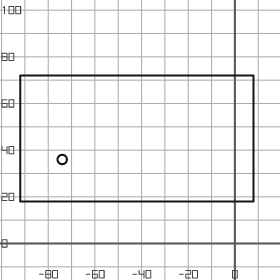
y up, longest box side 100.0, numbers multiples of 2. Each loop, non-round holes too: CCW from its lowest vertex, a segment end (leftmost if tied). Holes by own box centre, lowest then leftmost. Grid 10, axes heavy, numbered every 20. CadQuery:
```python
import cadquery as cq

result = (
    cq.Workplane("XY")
    .moveTo(-92.0, 18.0)
    .lineTo(8.0, 18.0)
    .lineTo(8.0, 72.0)
    .lineTo(-92.0, 72.0)
    .close()
    .moveTo(-74.0, 36.0)
    .circle(2.0)
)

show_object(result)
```